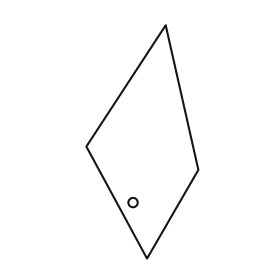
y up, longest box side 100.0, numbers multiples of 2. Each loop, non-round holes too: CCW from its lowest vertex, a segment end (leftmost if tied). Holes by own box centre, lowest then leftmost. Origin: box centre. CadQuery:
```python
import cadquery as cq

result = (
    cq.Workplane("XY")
    .moveTo(2.0, -50.0)
    .lineTo(24.0, -12.0)
    .lineTo(10.0, 50.0)
    .lineTo(-24.0, -2.0)
    .close()
    .moveTo(-4.0, -26.0)
    .circle(2.0)
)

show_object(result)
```